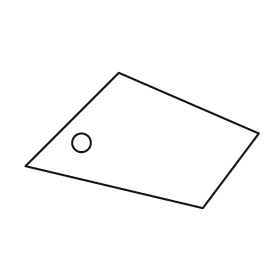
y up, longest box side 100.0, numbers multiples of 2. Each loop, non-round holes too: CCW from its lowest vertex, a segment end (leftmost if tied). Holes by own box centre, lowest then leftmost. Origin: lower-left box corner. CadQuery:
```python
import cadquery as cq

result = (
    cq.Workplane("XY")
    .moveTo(76.0, 0.0)
    .lineTo(100.0, 32.0)
    .lineTo(40.0, 58.0)
    .lineTo(0.0, 18.0)
    .close()
    .moveTo(24.0, 28.0)
    .circle(4.0)
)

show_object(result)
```